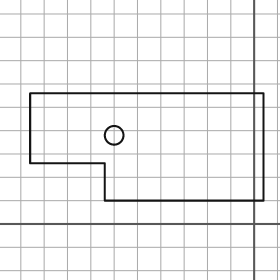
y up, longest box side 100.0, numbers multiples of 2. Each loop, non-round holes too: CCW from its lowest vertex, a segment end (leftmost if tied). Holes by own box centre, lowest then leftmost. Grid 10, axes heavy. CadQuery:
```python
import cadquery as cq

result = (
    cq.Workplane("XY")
    .moveTo(-64.0, 10.0)
    .lineTo(4.0, 10.0)
    .lineTo(4.0, 56.0)
    .lineTo(-96.0, 56.0)
    .lineTo(-96.0, 26.0)
    .lineTo(-64.0, 26.0)
    .close()
    .moveTo(-60.0, 38.0)
    .circle(4.0)
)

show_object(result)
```